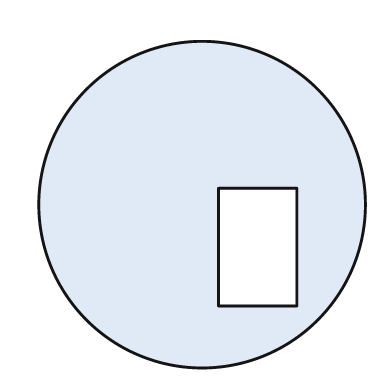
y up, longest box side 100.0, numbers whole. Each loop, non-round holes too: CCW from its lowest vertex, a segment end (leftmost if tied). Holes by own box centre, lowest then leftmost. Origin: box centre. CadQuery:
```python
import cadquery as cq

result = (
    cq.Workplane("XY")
    .moveTo(0.0, 0.0)
    .circle(50.0)
    .moveTo(5.0, -31.0)
    .lineTo(29.0, -31.0)
    .lineTo(29.0, 5.0)
    .lineTo(5.0, 5.0)
    .close()
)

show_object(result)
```